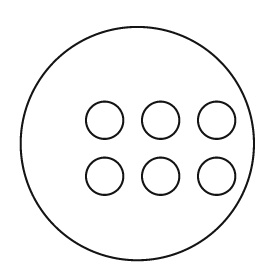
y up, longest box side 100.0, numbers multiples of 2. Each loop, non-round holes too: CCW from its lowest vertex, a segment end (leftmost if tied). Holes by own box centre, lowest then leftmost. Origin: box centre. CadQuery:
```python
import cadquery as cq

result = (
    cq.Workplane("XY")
    .moveTo(0.0, 0.0)
    .circle(50.0)
    .moveTo(-14.0, -14.0)
    .circle(8.0)
    .moveTo(10.0, -14.0)
    .circle(8.0)
    .moveTo(34.0, -14.0)
    .circle(8.0)
    .moveTo(-14.0, 10.0)
    .circle(8.0)
    .moveTo(10.0, 10.0)
    .circle(8.0)
    .moveTo(34.0, 10.0)
    .circle(8.0)
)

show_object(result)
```